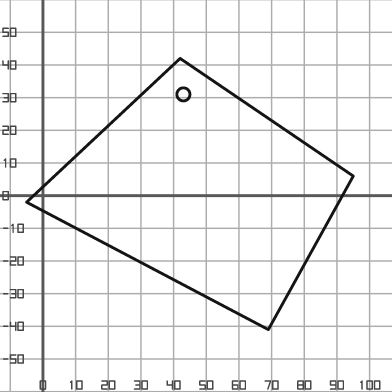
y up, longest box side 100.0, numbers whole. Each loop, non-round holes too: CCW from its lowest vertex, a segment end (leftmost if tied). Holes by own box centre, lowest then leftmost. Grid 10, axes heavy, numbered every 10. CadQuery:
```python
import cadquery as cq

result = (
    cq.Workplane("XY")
    .moveTo(69.0, -41.0)
    .lineTo(95.0, 6.0)
    .lineTo(42.0, 42.0)
    .lineTo(-5.0, -2.0)
    .close()
    .moveTo(43.0, 31.0)
    .circle(2.0)
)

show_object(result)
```